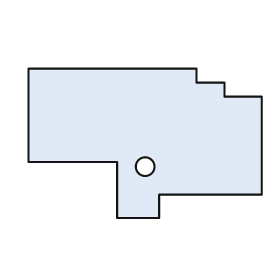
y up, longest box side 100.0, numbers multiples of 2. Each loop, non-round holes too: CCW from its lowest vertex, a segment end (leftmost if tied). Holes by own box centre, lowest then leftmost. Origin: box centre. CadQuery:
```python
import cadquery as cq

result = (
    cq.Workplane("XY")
    .moveTo(-12.0, -32.0)
    .lineTo(6.0, -32.0)
    .lineTo(6.0, -22.0)
    .lineTo(50.0, -22.0)
    .lineTo(50.0, 20.0)
    .lineTo(34.0, 20.0)
    .lineTo(34.0, 26.0)
    .lineTo(22.0, 26.0)
    .lineTo(22.0, 32.0)
    .lineTo(-50.0, 32.0)
    .lineTo(-50.0, -8.0)
    .lineTo(-12.0, -8.0)
    .close()
    .moveTo(0.0, -10.0)
    .circle(4.0)
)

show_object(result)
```